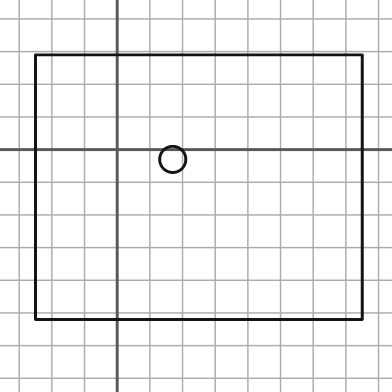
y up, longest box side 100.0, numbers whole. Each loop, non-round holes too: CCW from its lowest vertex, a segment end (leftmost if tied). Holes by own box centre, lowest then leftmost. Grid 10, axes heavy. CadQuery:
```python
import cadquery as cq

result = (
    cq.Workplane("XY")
    .moveTo(-25.0, -52.0)
    .lineTo(75.0, -52.0)
    .lineTo(75.0, 29.0)
    .lineTo(-25.0, 29.0)
    .close()
    .moveTo(17.0, -3.0)
    .circle(4.0)
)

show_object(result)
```